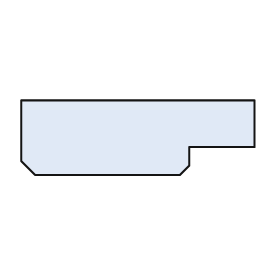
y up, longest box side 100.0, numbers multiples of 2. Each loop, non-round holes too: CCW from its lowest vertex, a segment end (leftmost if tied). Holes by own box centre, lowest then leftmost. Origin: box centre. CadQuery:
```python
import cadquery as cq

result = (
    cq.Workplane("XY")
    .moveTo(-44.0, -16.0)
    .lineTo(18.0, -16.0)
    .lineTo(22.0, -12.0)
    .lineTo(22.0, -4.0)
    .lineTo(50.0, -4.0)
    .lineTo(50.0, 16.0)
    .lineTo(-50.0, 16.0)
    .lineTo(-50.0, -10.0)
    .close()
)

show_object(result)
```